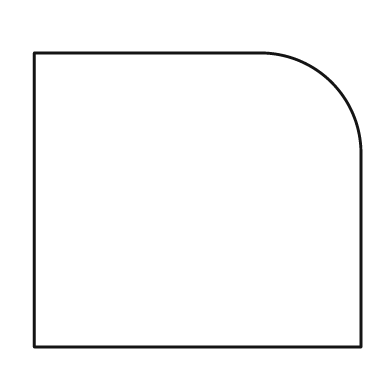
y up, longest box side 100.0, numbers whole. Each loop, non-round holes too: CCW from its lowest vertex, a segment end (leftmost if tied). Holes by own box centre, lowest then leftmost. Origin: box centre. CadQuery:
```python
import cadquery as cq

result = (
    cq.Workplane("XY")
    .moveTo(-50.0, -45.0)
    .lineTo(50.0, -45.0)
    .lineTo(50.0, 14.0)
    .threePointArc((41.0, 36.0), (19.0, 45.0))
    .lineTo(-50.0, 45.0)
    .close()
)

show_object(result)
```